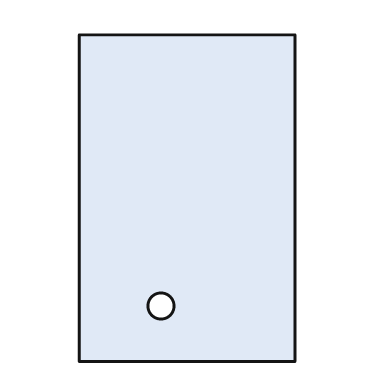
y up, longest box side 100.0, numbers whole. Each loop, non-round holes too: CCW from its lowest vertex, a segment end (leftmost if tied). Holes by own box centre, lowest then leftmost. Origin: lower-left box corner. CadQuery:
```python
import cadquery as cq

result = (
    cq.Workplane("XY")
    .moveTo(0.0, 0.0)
    .lineTo(66.0, 0.0)
    .lineTo(66.0, 100.0)
    .lineTo(0.0, 100.0)
    .close()
    .moveTo(25.0, 17.0)
    .circle(4.0)
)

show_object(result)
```